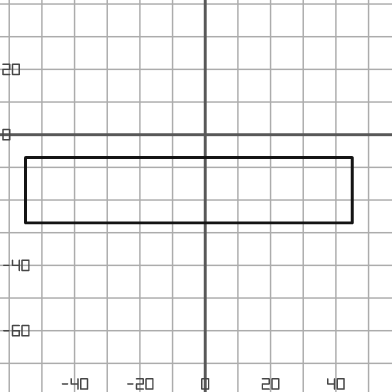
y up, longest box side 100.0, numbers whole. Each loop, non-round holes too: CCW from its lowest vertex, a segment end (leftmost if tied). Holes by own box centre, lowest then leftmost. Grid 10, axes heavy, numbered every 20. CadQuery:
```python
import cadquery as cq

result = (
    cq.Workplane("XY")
    .moveTo(-55.0, -27.0)
    .lineTo(45.0, -27.0)
    .lineTo(45.0, -7.0)
    .lineTo(-55.0, -7.0)
    .close()
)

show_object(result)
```